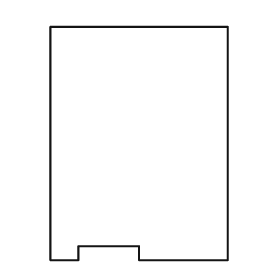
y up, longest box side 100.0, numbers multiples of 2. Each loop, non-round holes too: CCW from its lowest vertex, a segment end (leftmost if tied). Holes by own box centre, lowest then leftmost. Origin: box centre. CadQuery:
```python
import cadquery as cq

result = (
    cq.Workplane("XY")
    .moveTo(-38.0, -50.0)
    .lineTo(-26.0, -50.0)
    .lineTo(-26.0, -44.0)
    .lineTo(0.0, -44.0)
    .lineTo(0.0, -50.0)
    .lineTo(38.0, -50.0)
    .lineTo(38.0, 50.0)
    .lineTo(-38.0, 50.0)
    .close()
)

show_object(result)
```